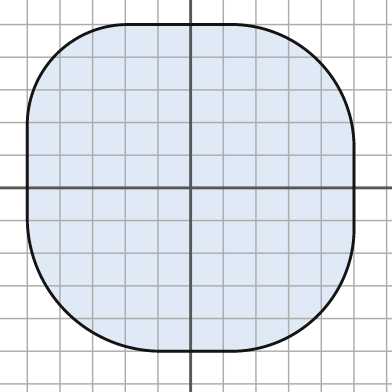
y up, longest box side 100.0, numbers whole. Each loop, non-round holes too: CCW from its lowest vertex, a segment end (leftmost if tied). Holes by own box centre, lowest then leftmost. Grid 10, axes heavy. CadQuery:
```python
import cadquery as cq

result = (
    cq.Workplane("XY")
    .moveTo(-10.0, -50.0)
    .lineTo(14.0, -50.0)
    .threePointArc((39.0, -39.0), (50.0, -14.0))
    .lineTo(50.0, 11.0)
    .threePointArc((39.0, 39.0), (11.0, 50.0))
    .lineTo(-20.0, 50.0)
    .threePointArc((-41.0, 41.0), (-50.0, 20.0))
    .lineTo(-50.0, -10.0)
    .threePointArc((-38.0, -38.0), (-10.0, -50.0))
    .close()
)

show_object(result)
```